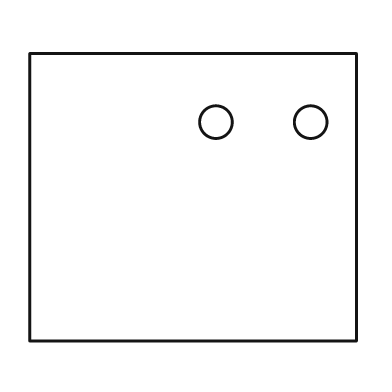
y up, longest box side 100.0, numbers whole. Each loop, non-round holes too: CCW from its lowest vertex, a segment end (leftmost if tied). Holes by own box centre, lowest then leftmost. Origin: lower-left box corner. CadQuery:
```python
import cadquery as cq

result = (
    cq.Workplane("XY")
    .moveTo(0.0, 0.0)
    .lineTo(100.0, 0.0)
    .lineTo(100.0, 88.0)
    .lineTo(0.0, 88.0)
    .close()
    .moveTo(57.0, 67.0)
    .circle(5.0)
    .moveTo(86.0, 67.0)
    .circle(5.0)
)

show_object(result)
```